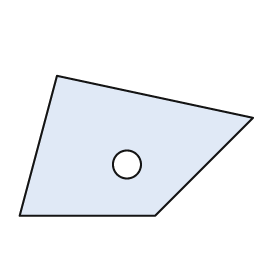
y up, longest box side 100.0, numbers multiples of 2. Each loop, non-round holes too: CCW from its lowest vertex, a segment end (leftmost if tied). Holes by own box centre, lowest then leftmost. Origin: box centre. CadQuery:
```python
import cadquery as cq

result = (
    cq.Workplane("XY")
    .moveTo(-50.0, -30.0)
    .lineTo(8.0, -30.0)
    .lineTo(50.0, 12.0)
    .lineTo(-34.0, 30.0)
    .close()
    .moveTo(-4.0, -8.0)
    .circle(6.0)
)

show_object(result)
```